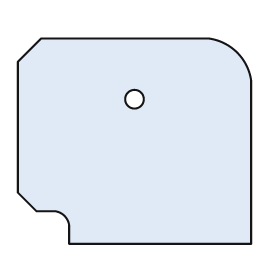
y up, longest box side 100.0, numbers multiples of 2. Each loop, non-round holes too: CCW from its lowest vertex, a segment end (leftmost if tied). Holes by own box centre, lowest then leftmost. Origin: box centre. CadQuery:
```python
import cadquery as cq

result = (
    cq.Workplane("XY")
    .moveTo(-28.0, -44.0)
    .lineTo(50.0, -44.0)
    .lineTo(50.0, 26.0)
    .threePointArc((44.0, 38.0), (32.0, 44.0))
    .lineTo(-40.0, 44.0)
    .lineTo(-50.0, 34.0)
    .lineTo(-50.0, -22.0)
    .lineTo(-42.0, -30.0)
    .lineTo(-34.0, -30.0)
    .threePointArc((-30.0, -32.0), (-28.0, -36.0))
    .close()
    .moveTo(0.0, 18.0)
    .circle(4.0)
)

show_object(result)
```